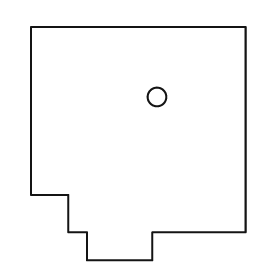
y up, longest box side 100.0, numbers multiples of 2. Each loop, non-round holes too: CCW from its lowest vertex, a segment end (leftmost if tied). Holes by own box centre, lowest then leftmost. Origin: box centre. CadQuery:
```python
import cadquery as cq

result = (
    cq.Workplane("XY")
    .moveTo(-22.0, -50.0)
    .lineTo(6.0, -50.0)
    .lineTo(6.0, -38.0)
    .lineTo(46.0, -38.0)
    .lineTo(46.0, 50.0)
    .lineTo(-46.0, 50.0)
    .lineTo(-46.0, -22.0)
    .lineTo(-30.0, -22.0)
    .lineTo(-30.0, -38.0)
    .lineTo(-22.0, -38.0)
    .close()
    .moveTo(8.0, 20.0)
    .circle(4.0)
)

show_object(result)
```